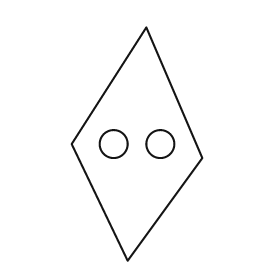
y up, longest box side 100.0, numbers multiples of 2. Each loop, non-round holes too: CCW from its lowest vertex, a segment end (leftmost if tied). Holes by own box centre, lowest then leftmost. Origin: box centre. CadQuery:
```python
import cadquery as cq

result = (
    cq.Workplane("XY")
    .moveTo(-4.0, -50.0)
    .lineTo(28.0, -6.0)
    .lineTo(4.0, 50.0)
    .lineTo(-28.0, 0.0)
    .close()
    .moveTo(-10.0, 0.0)
    .circle(6.0)
    .moveTo(10.0, 0.0)
    .circle(6.0)
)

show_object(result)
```